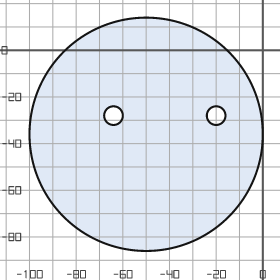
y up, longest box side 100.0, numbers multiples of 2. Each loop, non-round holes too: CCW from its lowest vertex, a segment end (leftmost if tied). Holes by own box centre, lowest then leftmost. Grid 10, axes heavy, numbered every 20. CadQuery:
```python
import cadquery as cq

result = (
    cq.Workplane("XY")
    .moveTo(-50.0, -36.0)
    .circle(50.0)
    .moveTo(-64.0, -28.0)
    .circle(4.0)
    .moveTo(-20.0, -28.0)
    .circle(4.0)
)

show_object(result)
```